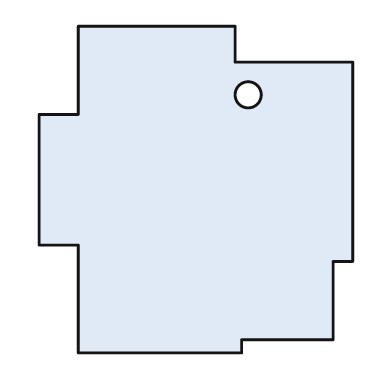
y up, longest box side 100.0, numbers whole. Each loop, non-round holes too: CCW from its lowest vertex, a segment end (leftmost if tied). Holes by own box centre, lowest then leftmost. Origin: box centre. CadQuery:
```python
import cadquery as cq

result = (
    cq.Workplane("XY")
    .moveTo(-36.0, -50.0)
    .lineTo(14.0, -50.0)
    .lineTo(14.0, -46.0)
    .lineTo(42.0, -46.0)
    .lineTo(42.0, -22.0)
    .lineTo(48.0, -22.0)
    .lineTo(48.0, 39.0)
    .lineTo(12.0, 39.0)
    .lineTo(12.0, 50.0)
    .lineTo(-36.0, 50.0)
    .lineTo(-36.0, 23.0)
    .lineTo(-48.0, 23.0)
    .lineTo(-48.0, -17.0)
    .lineTo(-36.0, -17.0)
    .close()
    .moveTo(16.0, 29.0)
    .circle(4.0)
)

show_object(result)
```